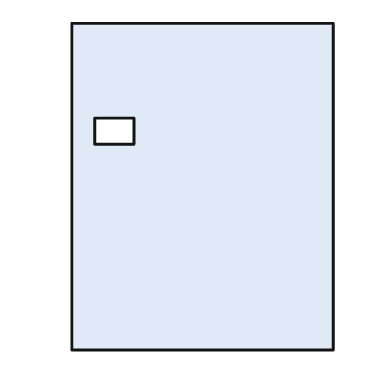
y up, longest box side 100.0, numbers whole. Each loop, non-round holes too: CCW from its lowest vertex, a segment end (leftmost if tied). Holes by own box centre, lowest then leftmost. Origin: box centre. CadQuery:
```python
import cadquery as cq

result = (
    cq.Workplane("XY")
    .moveTo(-40.0, -50.0)
    .lineTo(40.0, -50.0)
    .lineTo(40.0, 50.0)
    .lineTo(-40.0, 50.0)
    .close()
    .moveTo(-33.0, 13.0)
    .lineTo(-21.0, 13.0)
    .lineTo(-21.0, 21.0)
    .lineTo(-33.0, 21.0)
    .close()
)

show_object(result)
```